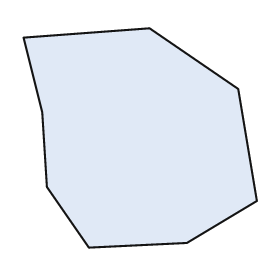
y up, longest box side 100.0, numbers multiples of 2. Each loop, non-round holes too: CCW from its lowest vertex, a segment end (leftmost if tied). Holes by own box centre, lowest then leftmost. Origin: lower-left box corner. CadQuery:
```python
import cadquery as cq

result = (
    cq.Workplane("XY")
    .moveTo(28.0, 0.0)
    .lineTo(70.0, 2.0)
    .lineTo(100.0, 20.0)
    .lineTo(92.0, 68.0)
    .lineTo(54.0, 94.0)
    .lineTo(0.0, 90.0)
    .lineTo(8.0, 58.0)
    .lineTo(10.0, 26.0)
    .close()
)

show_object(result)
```